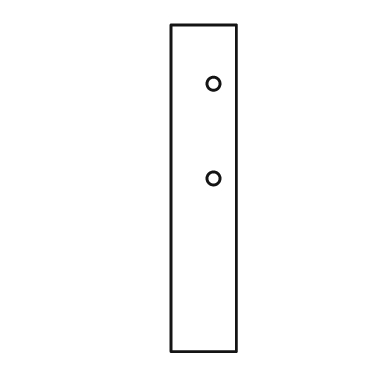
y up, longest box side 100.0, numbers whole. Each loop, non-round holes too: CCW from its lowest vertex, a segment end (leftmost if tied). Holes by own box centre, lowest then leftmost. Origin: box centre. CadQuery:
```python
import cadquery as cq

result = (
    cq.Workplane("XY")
    .moveTo(-10.0, -50.0)
    .lineTo(10.0, -50.0)
    .lineTo(10.0, 50.0)
    .lineTo(-10.0, 50.0)
    .close()
    .moveTo(3.0, 3.0)
    .circle(2.0)
    .moveTo(3.0, 32.0)
    .circle(2.0)
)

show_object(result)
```